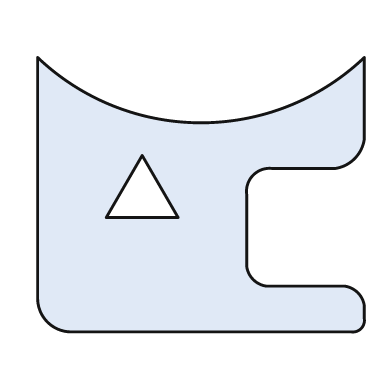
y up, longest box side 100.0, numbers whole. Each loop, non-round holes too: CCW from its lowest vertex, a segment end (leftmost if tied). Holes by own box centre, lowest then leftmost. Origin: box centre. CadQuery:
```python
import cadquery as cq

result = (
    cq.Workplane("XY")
    .moveTo(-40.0, -42.0)
    .lineTo(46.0, -42.0)
    .threePointArc((49.0, -41.0), (50.0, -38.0))
    .lineTo(50.0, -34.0)
    .threePointArc((48.0, -30.0), (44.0, -28.0))
    .lineTo(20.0, -28.0)
    .threePointArc((16.0, -26.0), (14.0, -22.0))
    .lineTo(14.0, 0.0)
    .threePointArc((16.0, 6.0), (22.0, 8.0))
    .lineTo(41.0, 8.0)
    .threePointArc((47.0, 11.0), (50.0, 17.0))
    .lineTo(50.0, 42.0)
    .threePointArc((0.0, 22.0), (-50.0, 42.0))
    .lineTo(-50.0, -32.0)
    .threePointArc((-47.0, -39.0), (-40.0, -42.0))
    .close()
    .moveTo(-29.0, -7.0)
    .lineTo(-7.0, -7.0)
    .lineTo(-18.0, 12.0)
    .close()
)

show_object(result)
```